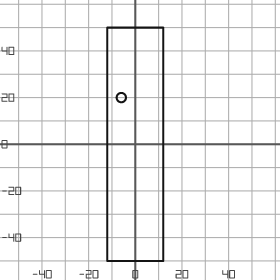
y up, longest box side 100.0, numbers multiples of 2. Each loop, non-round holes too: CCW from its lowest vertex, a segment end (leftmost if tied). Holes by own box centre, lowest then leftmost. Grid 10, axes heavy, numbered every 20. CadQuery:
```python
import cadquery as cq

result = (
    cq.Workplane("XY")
    .moveTo(-12.0, -50.0)
    .lineTo(12.0, -50.0)
    .lineTo(12.0, 50.0)
    .lineTo(-12.0, 50.0)
    .close()
    .moveTo(-6.0, 20.0)
    .circle(2.0)
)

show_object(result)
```